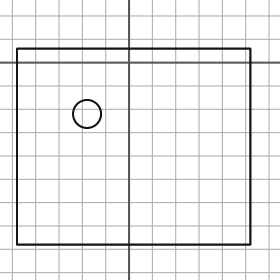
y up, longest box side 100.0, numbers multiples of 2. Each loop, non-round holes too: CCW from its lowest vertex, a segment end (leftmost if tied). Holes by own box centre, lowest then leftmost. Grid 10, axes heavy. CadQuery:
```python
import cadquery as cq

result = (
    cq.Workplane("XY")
    .moveTo(-48.0, -78.0)
    .lineTo(52.0, -78.0)
    .lineTo(52.0, 6.0)
    .lineTo(-48.0, 6.0)
    .close()
    .moveTo(-18.0, -22.0)
    .circle(6.0)
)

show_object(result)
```